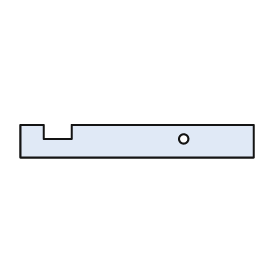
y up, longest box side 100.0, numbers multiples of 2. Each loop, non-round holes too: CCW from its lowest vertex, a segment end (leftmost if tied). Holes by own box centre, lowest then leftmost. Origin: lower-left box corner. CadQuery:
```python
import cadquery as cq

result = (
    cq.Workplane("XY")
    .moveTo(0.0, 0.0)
    .lineTo(100.0, 0.0)
    .lineTo(100.0, 14.0)
    .lineTo(22.0, 14.0)
    .lineTo(22.0, 8.0)
    .lineTo(10.0, 8.0)
    .lineTo(10.0, 14.0)
    .lineTo(0.0, 14.0)
    .close()
    .moveTo(70.0, 8.0)
    .circle(2.0)
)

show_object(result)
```